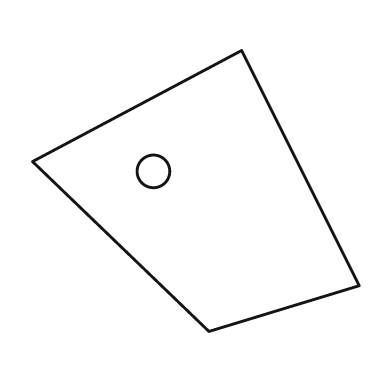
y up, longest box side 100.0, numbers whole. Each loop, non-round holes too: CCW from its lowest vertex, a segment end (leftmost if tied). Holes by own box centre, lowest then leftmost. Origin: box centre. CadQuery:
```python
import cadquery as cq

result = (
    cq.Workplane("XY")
    .moveTo(4.0, -43.0)
    .lineTo(50.0, -29.0)
    .lineTo(14.0, 43.0)
    .lineTo(-50.0, 9.0)
    .close()
    .moveTo(-13.0, 6.0)
    .circle(5.0)
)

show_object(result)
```